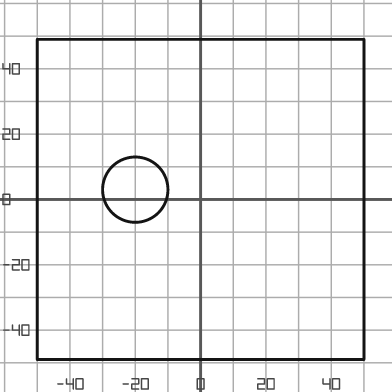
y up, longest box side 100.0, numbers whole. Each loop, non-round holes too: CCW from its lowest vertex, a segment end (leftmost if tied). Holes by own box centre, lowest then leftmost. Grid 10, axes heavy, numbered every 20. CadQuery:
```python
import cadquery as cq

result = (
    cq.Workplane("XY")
    .moveTo(-50.0, -49.0)
    .lineTo(50.0, -49.0)
    .lineTo(50.0, 49.0)
    .lineTo(-50.0, 49.0)
    .close()
    .moveTo(-20.0, 3.0)
    .circle(10.0)
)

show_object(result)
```